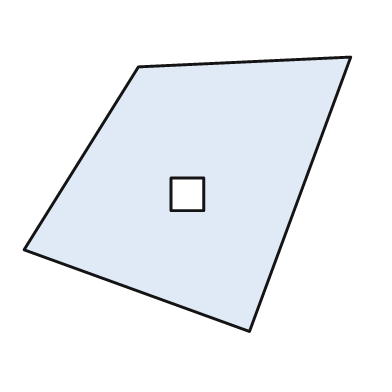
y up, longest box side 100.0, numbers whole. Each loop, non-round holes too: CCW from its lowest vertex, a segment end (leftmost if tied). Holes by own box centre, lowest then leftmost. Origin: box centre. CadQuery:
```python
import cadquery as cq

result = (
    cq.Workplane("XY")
    .moveTo(19.0, -42.0)
    .lineTo(50.0, 42.0)
    .lineTo(-15.0, 39.0)
    .lineTo(-50.0, -17.0)
    .close()
    .moveTo(-5.0, -5.0)
    .lineTo(5.0, -5.0)
    .lineTo(5.0, 5.0)
    .lineTo(-5.0, 5.0)
    .close()
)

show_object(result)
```